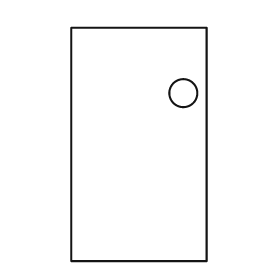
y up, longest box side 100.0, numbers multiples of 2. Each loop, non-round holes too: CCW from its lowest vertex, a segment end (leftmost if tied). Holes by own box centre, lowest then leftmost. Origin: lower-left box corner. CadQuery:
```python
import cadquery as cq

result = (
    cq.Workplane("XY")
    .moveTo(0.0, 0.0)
    .lineTo(58.0, 0.0)
    .lineTo(58.0, 100.0)
    .lineTo(0.0, 100.0)
    .close()
    .moveTo(48.0, 72.0)
    .circle(6.0)
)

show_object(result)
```